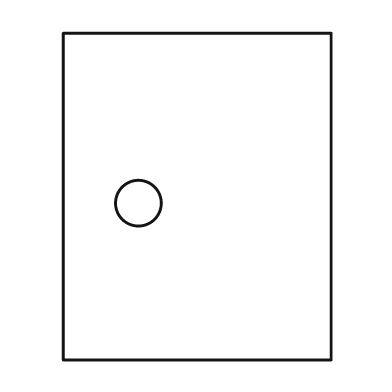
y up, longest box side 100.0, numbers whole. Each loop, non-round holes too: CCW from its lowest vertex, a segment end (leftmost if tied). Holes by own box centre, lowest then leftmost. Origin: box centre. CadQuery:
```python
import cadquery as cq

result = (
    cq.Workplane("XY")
    .moveTo(-41.0, -50.0)
    .lineTo(41.0, -50.0)
    .lineTo(41.0, 50.0)
    .lineTo(-41.0, 50.0)
    .close()
    .moveTo(-18.0, -2.0)
    .circle(7.0)
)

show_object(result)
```